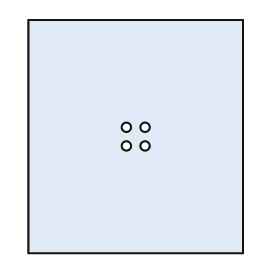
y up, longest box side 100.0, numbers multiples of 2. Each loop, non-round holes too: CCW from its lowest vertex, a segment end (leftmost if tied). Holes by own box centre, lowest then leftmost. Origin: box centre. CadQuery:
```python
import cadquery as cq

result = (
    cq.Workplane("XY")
    .moveTo(-46.0, -50.0)
    .lineTo(46.0, -50.0)
    .lineTo(46.0, 50.0)
    .lineTo(-46.0, 50.0)
    .close()
    .moveTo(-4.0, -4.0)
    .circle(2.0)
    .moveTo(4.0, -4.0)
    .circle(2.0)
    .moveTo(-4.0, 4.0)
    .circle(2.0)
    .moveTo(4.0, 4.0)
    .circle(2.0)
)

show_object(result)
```